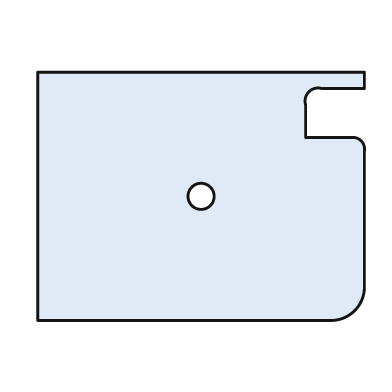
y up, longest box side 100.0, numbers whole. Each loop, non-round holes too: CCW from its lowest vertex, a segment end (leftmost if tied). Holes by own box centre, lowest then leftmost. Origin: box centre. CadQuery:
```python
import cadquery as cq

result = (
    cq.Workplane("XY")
    .moveTo(-50.0, -38.0)
    .lineTo(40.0, -38.0)
    .threePointArc((47.0, -35.0), (50.0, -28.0))
    .lineTo(50.0, 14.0)
    .threePointArc((49.0, 17.0), (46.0, 18.0))
    .lineTo(32.0, 18.0)
    .lineTo(32.0, 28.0)
    .threePointArc((33.0, 32.0), (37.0, 33.0))
    .lineTo(50.0, 33.0)
    .lineTo(50.0, 38.0)
    .lineTo(-50.0, 38.0)
    .close()
    .moveTo(0.0, 0.0)
    .circle(4.0)
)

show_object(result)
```